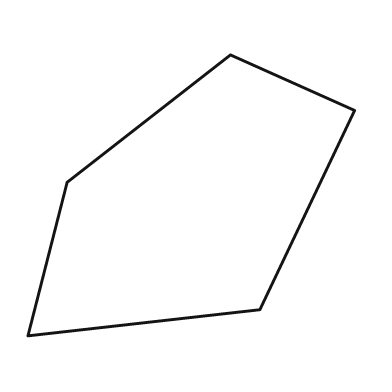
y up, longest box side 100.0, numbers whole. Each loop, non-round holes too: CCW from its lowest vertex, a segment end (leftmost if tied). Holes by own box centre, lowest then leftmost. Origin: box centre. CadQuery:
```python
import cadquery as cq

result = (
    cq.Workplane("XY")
    .moveTo(-50.0, -43.0)
    .lineTo(21.0, -35.0)
    .lineTo(50.0, 26.0)
    .lineTo(12.0, 43.0)
    .lineTo(-38.0, 4.0)
    .close()
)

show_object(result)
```